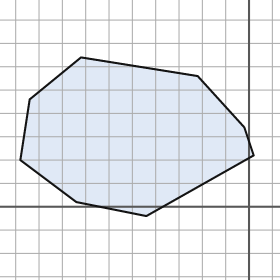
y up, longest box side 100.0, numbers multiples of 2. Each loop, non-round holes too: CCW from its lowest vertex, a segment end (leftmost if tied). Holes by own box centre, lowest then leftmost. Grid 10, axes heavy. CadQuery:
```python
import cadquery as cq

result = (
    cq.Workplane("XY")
    .moveTo(-44.0, -4.0)
    .lineTo(2.0, 22.0)
    .lineTo(-2.0, 34.0)
    .lineTo(-22.0, 56.0)
    .lineTo(-72.0, 64.0)
    .lineTo(-94.0, 46.0)
    .lineTo(-98.0, 20.0)
    .lineTo(-74.0, 2.0)
    .close()
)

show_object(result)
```